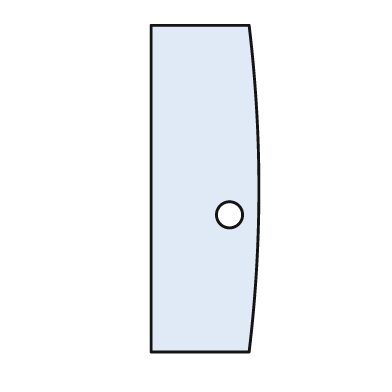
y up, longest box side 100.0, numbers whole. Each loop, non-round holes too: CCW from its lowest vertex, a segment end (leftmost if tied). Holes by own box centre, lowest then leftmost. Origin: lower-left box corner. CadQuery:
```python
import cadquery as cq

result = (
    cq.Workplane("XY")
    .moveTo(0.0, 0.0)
    .lineTo(30.0, 0.0)
    .threePointArc((33.0, 50.0), (30.0, 100.0))
    .lineTo(0.0, 100.0)
    .close()
    .moveTo(24.0, 42.0)
    .circle(4.0)
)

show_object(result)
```